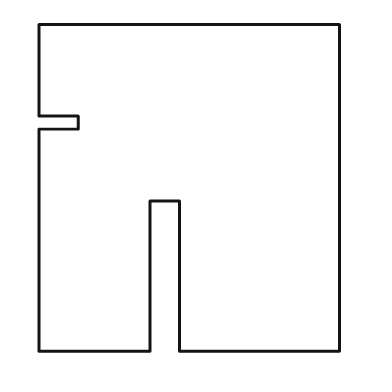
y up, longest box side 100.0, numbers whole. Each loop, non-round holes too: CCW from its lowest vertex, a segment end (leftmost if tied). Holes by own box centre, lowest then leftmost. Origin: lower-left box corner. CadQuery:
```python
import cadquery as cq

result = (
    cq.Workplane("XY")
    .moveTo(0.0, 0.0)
    .lineTo(34.0, 0.0)
    .lineTo(34.0, 46.0)
    .lineTo(43.0, 46.0)
    .lineTo(43.0, 0.0)
    .lineTo(92.0, 0.0)
    .lineTo(92.0, 100.0)
    .lineTo(0.0, 100.0)
    .lineTo(0.0, 72.0)
    .lineTo(12.0, 72.0)
    .lineTo(12.0, 68.0)
    .lineTo(0.0, 68.0)
    .close()
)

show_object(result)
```